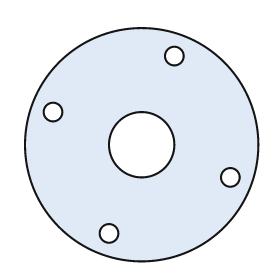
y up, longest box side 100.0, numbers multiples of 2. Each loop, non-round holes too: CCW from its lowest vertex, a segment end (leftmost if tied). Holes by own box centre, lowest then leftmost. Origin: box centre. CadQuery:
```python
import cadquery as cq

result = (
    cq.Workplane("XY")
    .moveTo(0.0, 0.0)
    .circle(50.0)
    .moveTo(-14.0, -38.0)
    .circle(4.0)
    .moveTo(38.0, -14.0)
    .circle(4.0)
    .moveTo(0.0, 0.0)
    .circle(14.0)
    .moveTo(-38.0, 14.0)
    .circle(4.0)
    .moveTo(14.0, 38.0)
    .circle(4.0)
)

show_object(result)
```